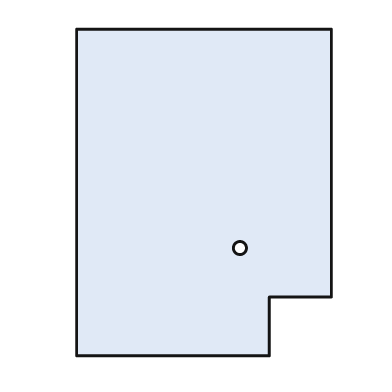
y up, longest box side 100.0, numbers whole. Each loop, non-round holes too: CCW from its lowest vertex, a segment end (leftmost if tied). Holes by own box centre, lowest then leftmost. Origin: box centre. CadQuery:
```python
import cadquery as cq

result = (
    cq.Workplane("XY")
    .moveTo(-39.0, -50.0)
    .lineTo(20.0, -50.0)
    .lineTo(20.0, -32.0)
    .lineTo(39.0, -32.0)
    .lineTo(39.0, 50.0)
    .lineTo(-39.0, 50.0)
    .close()
    .moveTo(11.0, -17.0)
    .circle(2.0)
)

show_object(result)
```